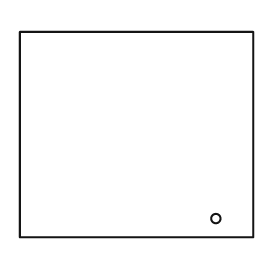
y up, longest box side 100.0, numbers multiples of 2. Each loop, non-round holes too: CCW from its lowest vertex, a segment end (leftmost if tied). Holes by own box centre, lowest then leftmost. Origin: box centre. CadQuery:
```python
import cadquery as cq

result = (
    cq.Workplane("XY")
    .moveTo(-50.0, -44.0)
    .lineTo(50.0, -44.0)
    .lineTo(50.0, 44.0)
    .lineTo(-50.0, 44.0)
    .close()
    .moveTo(34.0, -36.0)
    .circle(2.0)
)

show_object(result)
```